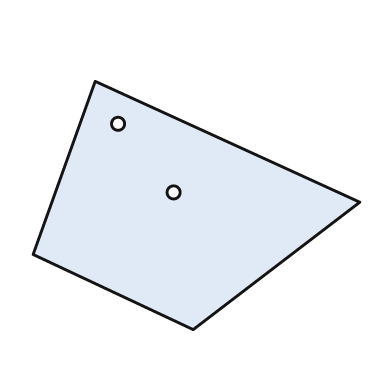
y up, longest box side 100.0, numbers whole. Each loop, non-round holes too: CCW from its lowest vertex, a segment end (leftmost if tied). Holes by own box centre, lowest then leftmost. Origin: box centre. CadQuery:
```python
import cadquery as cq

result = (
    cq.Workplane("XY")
    .moveTo(-1.0, -38.0)
    .lineTo(50.0, 1.0)
    .lineTo(-31.0, 38.0)
    .lineTo(-50.0, -15.0)
    .close()
    .moveTo(-7.0, 4.0)
    .circle(2.0)
    .moveTo(-24.0, 25.0)
    .circle(2.0)
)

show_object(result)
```